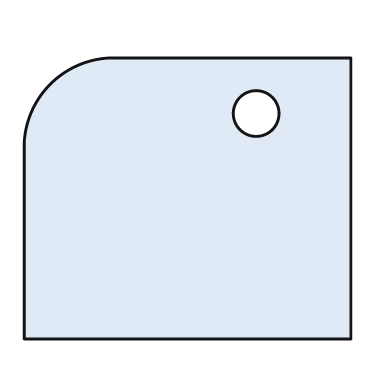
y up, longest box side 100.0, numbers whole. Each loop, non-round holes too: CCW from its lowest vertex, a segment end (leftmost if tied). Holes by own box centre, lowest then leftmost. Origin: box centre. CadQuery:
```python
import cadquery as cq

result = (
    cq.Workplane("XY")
    .moveTo(-50.0, -43.0)
    .lineTo(50.0, -43.0)
    .lineTo(50.0, 43.0)
    .lineTo(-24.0, 43.0)
    .threePointArc((-42.0, 35.0), (-50.0, 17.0))
    .close()
    .moveTo(21.0, 26.0)
    .circle(7.0)
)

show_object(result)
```